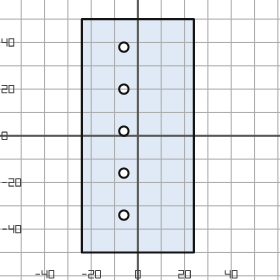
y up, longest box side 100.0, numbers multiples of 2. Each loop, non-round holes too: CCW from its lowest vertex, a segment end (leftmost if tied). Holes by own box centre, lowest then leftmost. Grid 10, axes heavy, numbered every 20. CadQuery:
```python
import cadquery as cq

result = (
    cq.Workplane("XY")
    .moveTo(-24.0, -50.0)
    .lineTo(24.0, -50.0)
    .lineTo(24.0, 50.0)
    .lineTo(-24.0, 50.0)
    .close()
    .moveTo(-6.0, -34.0)
    .circle(2.0)
    .moveTo(-6.0, -16.0)
    .circle(2.0)
    .moveTo(-6.0, 2.0)
    .circle(2.0)
    .moveTo(-6.0, 20.0)
    .circle(2.0)
    .moveTo(-6.0, 38.0)
    .circle(2.0)
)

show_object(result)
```